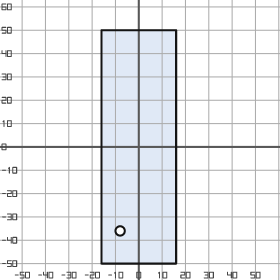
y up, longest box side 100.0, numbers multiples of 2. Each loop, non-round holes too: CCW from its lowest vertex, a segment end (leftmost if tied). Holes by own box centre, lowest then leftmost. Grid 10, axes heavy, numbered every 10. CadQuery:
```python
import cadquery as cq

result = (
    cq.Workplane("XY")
    .moveTo(-16.0, -50.0)
    .lineTo(16.0, -50.0)
    .lineTo(16.0, 50.0)
    .lineTo(-16.0, 50.0)
    .close()
    .moveTo(-8.0, -36.0)
    .circle(2.0)
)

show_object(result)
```